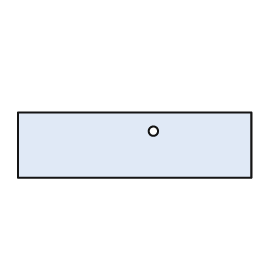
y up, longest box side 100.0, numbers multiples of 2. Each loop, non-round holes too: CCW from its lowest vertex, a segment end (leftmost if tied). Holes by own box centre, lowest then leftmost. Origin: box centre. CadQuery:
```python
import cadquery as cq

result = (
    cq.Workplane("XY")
    .moveTo(-50.0, -14.0)
    .lineTo(50.0, -14.0)
    .lineTo(50.0, 14.0)
    .lineTo(-50.0, 14.0)
    .close()
    .moveTo(8.0, 6.0)
    .circle(2.0)
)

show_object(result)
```